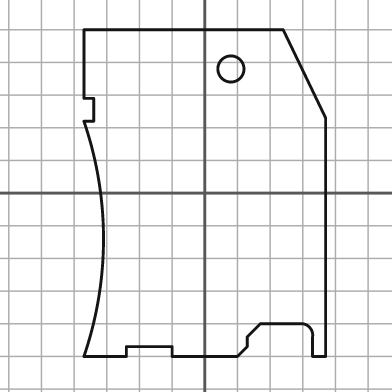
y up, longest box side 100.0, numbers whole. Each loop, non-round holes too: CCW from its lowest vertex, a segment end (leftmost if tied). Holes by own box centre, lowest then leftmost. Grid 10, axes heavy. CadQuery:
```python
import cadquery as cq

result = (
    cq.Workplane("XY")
    .moveTo(-37.0, -50.0)
    .lineTo(-24.0, -50.0)
    .lineTo(-24.0, -47.0)
    .lineTo(-10.0, -47.0)
    .lineTo(-10.0, -50.0)
    .lineTo(10.0, -50.0)
    .lineTo(13.0, -47.0)
    .lineTo(13.0, -44.0)
    .lineTo(17.0, -40.0)
    .lineTo(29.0, -40.0)
    .threePointArc((32.0, -41.0), (33.0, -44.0))
    .lineTo(33.0, -50.0)
    .lineTo(37.0, -50.0)
    .lineTo(37.0, 23.0)
    .lineTo(24.0, 50.0)
    .lineTo(-37.0, 50.0)
    .lineTo(-37.0, 29.0)
    .lineTo(-34.0, 29.0)
    .lineTo(-34.0, 22.0)
    .lineTo(-37.0, 22.0)
    .threePointArc((-31.0, -14.0), (-37.0, -50.0))
    .close()
    .moveTo(8.0, 38.0)
    .circle(4.0)
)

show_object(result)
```